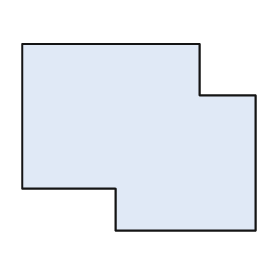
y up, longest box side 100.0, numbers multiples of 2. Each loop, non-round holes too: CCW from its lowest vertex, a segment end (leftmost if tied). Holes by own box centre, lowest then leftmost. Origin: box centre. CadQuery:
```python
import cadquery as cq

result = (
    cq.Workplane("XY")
    .moveTo(-10.0, -40.0)
    .lineTo(50.0, -40.0)
    .lineTo(50.0, 18.0)
    .lineTo(26.0, 18.0)
    .lineTo(26.0, 40.0)
    .lineTo(-50.0, 40.0)
    .lineTo(-50.0, -22.0)
    .lineTo(-10.0, -22.0)
    .close()
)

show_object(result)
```